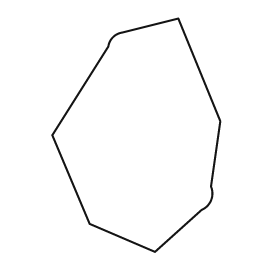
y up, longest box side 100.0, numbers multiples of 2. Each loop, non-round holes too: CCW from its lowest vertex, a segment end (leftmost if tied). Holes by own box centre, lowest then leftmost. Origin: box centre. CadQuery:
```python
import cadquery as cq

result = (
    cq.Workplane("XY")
    .moveTo(8.0, -50.0)
    .lineTo(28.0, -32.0)
    .threePointArc((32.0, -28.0), (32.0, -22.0))
    .lineTo(36.0, 6.0)
    .lineTo(18.0, 50.0)
    .lineTo(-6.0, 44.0)
    .threePointArc((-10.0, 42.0), (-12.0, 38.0))
    .lineTo(-36.0, 0.0)
    .lineTo(-20.0, -38.0)
    .close()
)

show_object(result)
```